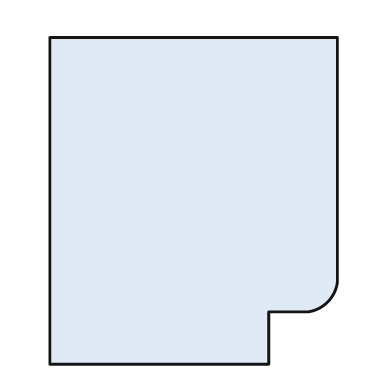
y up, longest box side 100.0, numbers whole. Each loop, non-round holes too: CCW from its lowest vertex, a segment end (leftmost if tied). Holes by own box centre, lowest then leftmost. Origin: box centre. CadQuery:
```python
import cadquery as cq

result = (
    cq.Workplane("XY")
    .moveTo(-44.0, -50.0)
    .lineTo(23.0, -50.0)
    .lineTo(23.0, -34.0)
    .lineTo(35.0, -34.0)
    .threePointArc((41.0, -31.0), (44.0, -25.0))
    .lineTo(44.0, 50.0)
    .lineTo(-44.0, 50.0)
    .close()
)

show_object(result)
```